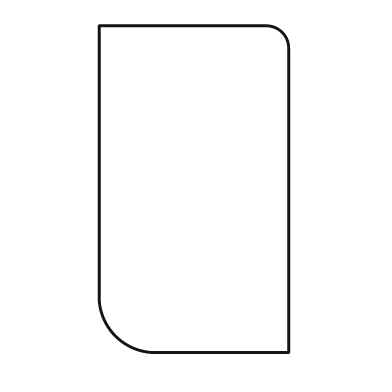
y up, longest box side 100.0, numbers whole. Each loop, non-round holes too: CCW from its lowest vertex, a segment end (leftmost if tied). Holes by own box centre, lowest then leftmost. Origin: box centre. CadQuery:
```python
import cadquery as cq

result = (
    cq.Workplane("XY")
    .moveTo(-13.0, -50.0)
    .lineTo(29.0, -50.0)
    .lineTo(29.0, 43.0)
    .threePointArc((27.0, 48.0), (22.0, 50.0))
    .lineTo(-29.0, 50.0)
    .lineTo(-29.0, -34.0)
    .threePointArc((-24.0, -45.0), (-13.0, -50.0))
    .close()
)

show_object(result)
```